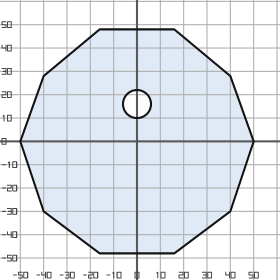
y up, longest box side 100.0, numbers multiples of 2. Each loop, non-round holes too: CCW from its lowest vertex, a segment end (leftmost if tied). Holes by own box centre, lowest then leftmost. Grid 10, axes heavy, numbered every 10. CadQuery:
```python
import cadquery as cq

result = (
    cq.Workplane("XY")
    .moveTo(-16.0, -48.0)
    .lineTo(16.0, -48.0)
    .lineTo(40.0, -30.0)
    .lineTo(50.0, 0.0)
    .lineTo(40.0, 28.0)
    .lineTo(16.0, 48.0)
    .lineTo(-16.0, 48.0)
    .lineTo(-40.0, 28.0)
    .lineTo(-50.0, 0.0)
    .lineTo(-40.0, -30.0)
    .close()
    .moveTo(0.0, 16.0)
    .circle(6.0)
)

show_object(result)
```